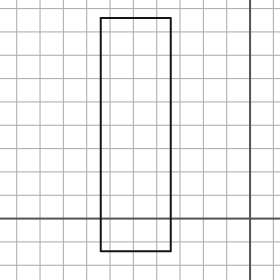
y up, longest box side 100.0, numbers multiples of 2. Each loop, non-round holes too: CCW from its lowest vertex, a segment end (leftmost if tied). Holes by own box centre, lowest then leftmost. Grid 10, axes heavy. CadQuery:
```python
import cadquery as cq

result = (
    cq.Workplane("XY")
    .moveTo(-64.0, -14.0)
    .lineTo(-34.0, -14.0)
    .lineTo(-34.0, 86.0)
    .lineTo(-64.0, 86.0)
    .close()
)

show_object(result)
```